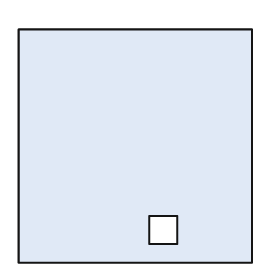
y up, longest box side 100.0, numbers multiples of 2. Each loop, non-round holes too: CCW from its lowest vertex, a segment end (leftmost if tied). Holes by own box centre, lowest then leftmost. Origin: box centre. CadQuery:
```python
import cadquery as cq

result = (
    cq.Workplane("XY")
    .moveTo(-50.0, -50.0)
    .lineTo(50.0, -50.0)
    .lineTo(50.0, 50.0)
    .lineTo(-50.0, 50.0)
    .close()
    .moveTo(6.0, -42.0)
    .lineTo(18.0, -42.0)
    .lineTo(18.0, -30.0)
    .lineTo(6.0, -30.0)
    .close()
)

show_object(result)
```